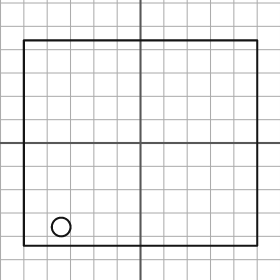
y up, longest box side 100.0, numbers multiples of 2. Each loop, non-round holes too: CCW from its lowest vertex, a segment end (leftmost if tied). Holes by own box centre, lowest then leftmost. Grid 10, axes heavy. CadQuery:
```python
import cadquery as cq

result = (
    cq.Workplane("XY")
    .moveTo(-50.0, -44.0)
    .lineTo(50.0, -44.0)
    .lineTo(50.0, 44.0)
    .lineTo(-50.0, 44.0)
    .close()
    .moveTo(-34.0, -36.0)
    .circle(4.0)
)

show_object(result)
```